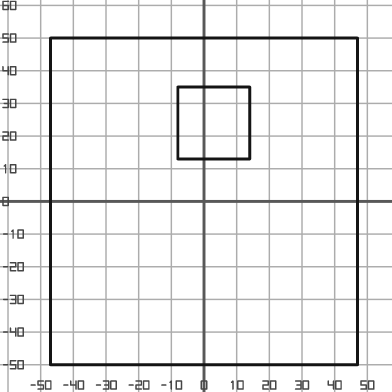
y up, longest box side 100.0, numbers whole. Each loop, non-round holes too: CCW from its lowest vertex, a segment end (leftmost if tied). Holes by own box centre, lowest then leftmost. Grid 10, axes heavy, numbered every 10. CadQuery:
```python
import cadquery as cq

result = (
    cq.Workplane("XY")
    .moveTo(-47.0, -50.0)
    .lineTo(47.0, -50.0)
    .lineTo(47.0, 50.0)
    .lineTo(-47.0, 50.0)
    .close()
    .moveTo(-8.0, 13.0)
    .lineTo(14.0, 13.0)
    .lineTo(14.0, 35.0)
    .lineTo(-8.0, 35.0)
    .close()
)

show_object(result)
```